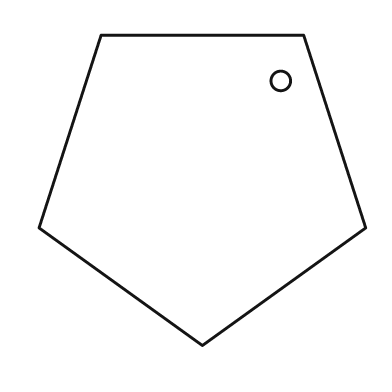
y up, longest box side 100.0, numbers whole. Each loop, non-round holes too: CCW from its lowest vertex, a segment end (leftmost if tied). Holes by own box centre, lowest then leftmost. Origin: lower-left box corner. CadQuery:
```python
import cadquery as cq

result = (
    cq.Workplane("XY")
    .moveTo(50.0, 0.0)
    .lineTo(100.0, 36.0)
    .lineTo(81.0, 95.0)
    .lineTo(19.0, 95.0)
    .lineTo(0.0, 36.0)
    .close()
    .moveTo(74.0, 81.0)
    .circle(3.0)
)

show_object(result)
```